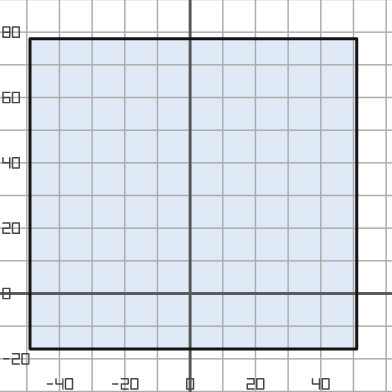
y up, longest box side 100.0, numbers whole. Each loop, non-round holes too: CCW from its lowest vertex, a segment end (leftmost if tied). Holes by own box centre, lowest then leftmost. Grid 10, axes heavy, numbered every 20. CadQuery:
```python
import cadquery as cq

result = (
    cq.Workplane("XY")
    .moveTo(-49.0, -17.0)
    .lineTo(51.0, -17.0)
    .lineTo(51.0, 78.0)
    .lineTo(-49.0, 78.0)
    .close()
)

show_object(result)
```